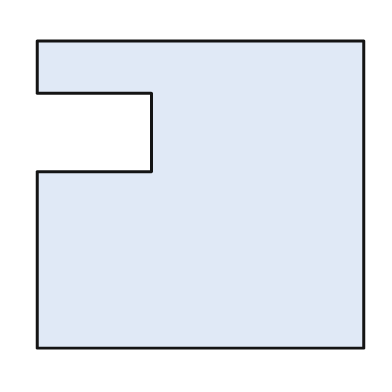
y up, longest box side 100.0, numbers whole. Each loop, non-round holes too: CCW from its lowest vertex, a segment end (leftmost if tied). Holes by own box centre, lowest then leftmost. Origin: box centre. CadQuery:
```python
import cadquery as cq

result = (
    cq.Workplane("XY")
    .moveTo(-50.0, -47.0)
    .lineTo(50.0, -47.0)
    .lineTo(50.0, 47.0)
    .lineTo(-50.0, 47.0)
    .lineTo(-50.0, 31.0)
    .lineTo(-15.0, 31.0)
    .lineTo(-15.0, 7.0)
    .lineTo(-50.0, 7.0)
    .close()
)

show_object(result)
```